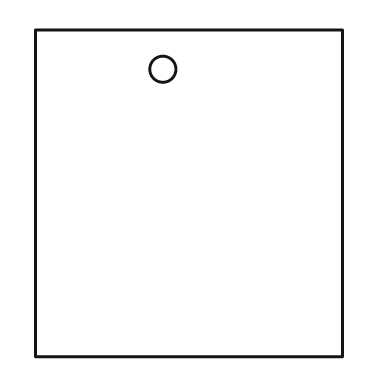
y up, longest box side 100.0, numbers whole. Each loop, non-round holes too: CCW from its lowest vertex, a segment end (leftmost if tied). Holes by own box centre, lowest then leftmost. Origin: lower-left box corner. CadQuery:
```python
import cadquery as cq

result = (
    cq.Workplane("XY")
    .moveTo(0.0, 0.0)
    .lineTo(94.0, 0.0)
    .lineTo(94.0, 100.0)
    .lineTo(0.0, 100.0)
    .close()
    .moveTo(39.0, 88.0)
    .circle(4.0)
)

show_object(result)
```